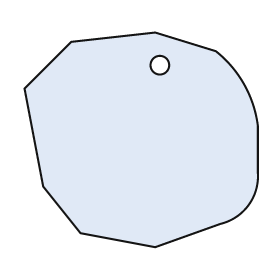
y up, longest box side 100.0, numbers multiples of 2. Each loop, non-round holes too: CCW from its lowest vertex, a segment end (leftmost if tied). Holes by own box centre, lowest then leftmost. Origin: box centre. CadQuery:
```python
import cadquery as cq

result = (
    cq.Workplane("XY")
    .moveTo(6.0, -46.0)
    .lineTo(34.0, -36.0)
    .threePointArc((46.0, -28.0), (50.0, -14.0))
    .lineTo(50.0, 6.0)
    .threePointArc((44.0, 24.0), (32.0, 38.0))
    .lineTo(6.0, 46.0)
    .lineTo(-30.0, 42.0)
    .lineTo(-50.0, 22.0)
    .lineTo(-42.0, -20.0)
    .lineTo(-26.0, -40.0)
    .close()
    .moveTo(8.0, 32.0)
    .circle(4.0)
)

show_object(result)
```